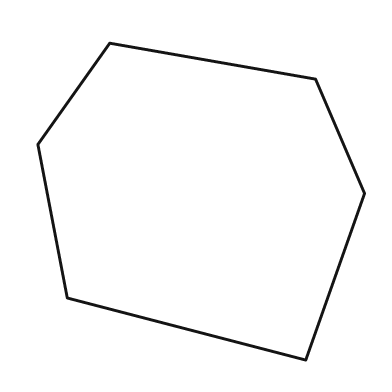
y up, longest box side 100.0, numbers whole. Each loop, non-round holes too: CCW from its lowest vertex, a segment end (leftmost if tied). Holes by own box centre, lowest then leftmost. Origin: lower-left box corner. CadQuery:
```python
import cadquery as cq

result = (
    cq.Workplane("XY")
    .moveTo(82.0, 0.0)
    .lineTo(100.0, 51.0)
    .lineTo(85.0, 86.0)
    .lineTo(22.0, 97.0)
    .lineTo(0.0, 66.0)
    .lineTo(9.0, 19.0)
    .close()
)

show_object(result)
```